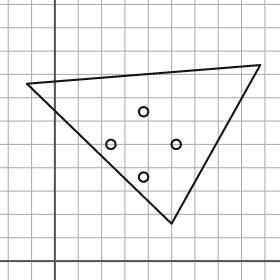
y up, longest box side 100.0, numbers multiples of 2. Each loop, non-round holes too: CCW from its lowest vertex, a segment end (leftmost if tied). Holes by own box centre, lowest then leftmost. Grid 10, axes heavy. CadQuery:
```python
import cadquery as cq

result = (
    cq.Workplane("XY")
    .moveTo(50.0, 16.0)
    .lineTo(88.0, 84.0)
    .lineTo(-12.0, 76.0)
    .close()
    .moveTo(38.0, 36.0)
    .circle(2.0)
    .moveTo(24.0, 50.0)
    .circle(2.0)
    .moveTo(52.0, 50.0)
    .circle(2.0)
    .moveTo(38.0, 64.0)
    .circle(2.0)
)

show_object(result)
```